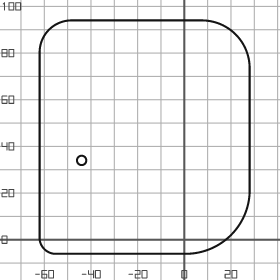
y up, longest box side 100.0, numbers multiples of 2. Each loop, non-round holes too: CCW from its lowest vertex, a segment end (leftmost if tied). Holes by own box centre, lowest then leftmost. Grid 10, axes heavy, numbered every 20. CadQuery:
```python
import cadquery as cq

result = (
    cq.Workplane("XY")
    .moveTo(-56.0, -6.0)
    .lineTo(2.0, -6.0)
    .threePointArc((20.0, 2.0), (28.0, 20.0))
    .lineTo(28.0, 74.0)
    .threePointArc((22.0, 88.0), (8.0, 94.0))
    .lineTo(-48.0, 94.0)
    .threePointArc((-58.0, 90.0), (-62.0, 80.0))
    .lineTo(-62.0, 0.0)
    .threePointArc((-60.0, -4.0), (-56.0, -6.0))
    .close()
    .moveTo(-44.0, 34.0)
    .circle(2.0)
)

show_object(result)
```